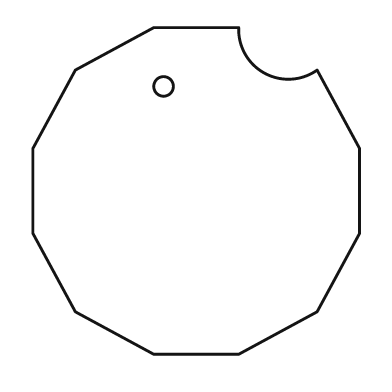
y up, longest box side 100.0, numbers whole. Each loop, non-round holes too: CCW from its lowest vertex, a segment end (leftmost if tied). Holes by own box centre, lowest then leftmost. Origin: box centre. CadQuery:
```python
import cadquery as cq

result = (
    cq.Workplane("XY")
    .moveTo(-13.0, -50.0)
    .lineTo(13.0, -50.0)
    .lineTo(37.0, -37.0)
    .lineTo(50.0, -13.0)
    .lineTo(50.0, 13.0)
    .lineTo(37.0, 37.0)
    .threePointArc((21.0, 36.0), (13.0, 50.0))
    .lineTo(-13.0, 50.0)
    .lineTo(-37.0, 37.0)
    .lineTo(-50.0, 13.0)
    .lineTo(-50.0, -13.0)
    .lineTo(-37.0, -37.0)
    .close()
    .moveTo(-10.0, 32.0)
    .circle(3.0)
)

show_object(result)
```